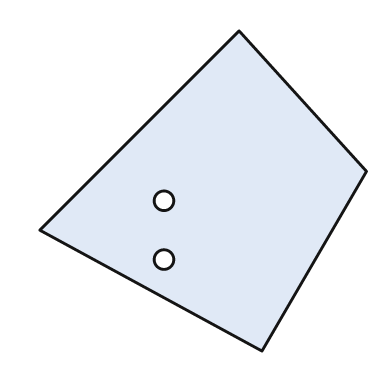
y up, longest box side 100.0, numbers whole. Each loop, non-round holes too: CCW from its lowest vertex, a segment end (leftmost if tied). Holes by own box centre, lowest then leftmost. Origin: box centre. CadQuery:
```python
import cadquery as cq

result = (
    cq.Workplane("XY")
    .moveTo(18.0, -49.0)
    .lineTo(50.0, 6.0)
    .lineTo(11.0, 49.0)
    .lineTo(-50.0, -12.0)
    .close()
    .moveTo(-12.0, -21.0)
    .circle(3.0)
    .moveTo(-12.0, -3.0)
    .circle(3.0)
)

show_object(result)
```